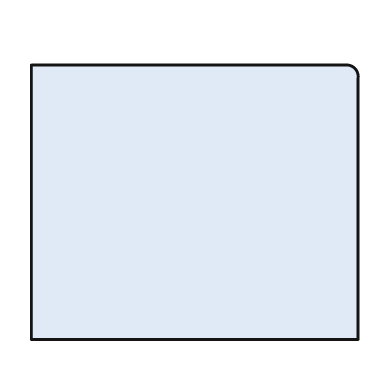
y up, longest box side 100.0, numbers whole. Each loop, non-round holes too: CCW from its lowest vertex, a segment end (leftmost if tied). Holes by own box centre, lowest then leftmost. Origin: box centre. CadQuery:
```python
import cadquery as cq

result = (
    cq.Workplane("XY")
    .moveTo(-50.0, -42.0)
    .lineTo(50.0, -42.0)
    .lineTo(50.0, 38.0)
    .threePointArc((49.0, 41.0), (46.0, 42.0))
    .lineTo(-50.0, 42.0)
    .close()
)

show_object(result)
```